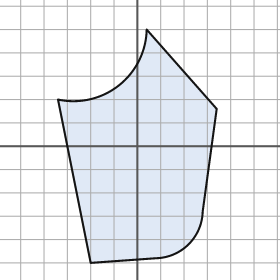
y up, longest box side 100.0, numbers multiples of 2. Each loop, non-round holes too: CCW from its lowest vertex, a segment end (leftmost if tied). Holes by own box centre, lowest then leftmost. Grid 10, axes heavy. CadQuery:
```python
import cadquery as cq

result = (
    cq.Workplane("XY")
    .moveTo(-20.0, -50.0)
    .lineTo(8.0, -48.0)
    .threePointArc((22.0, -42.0), (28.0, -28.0))
    .lineTo(34.0, 16.0)
    .lineTo(4.0, 50.0)
    .threePointArc((-8.0, 26.0), (-34.0, 20.0))
    .close()
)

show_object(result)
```